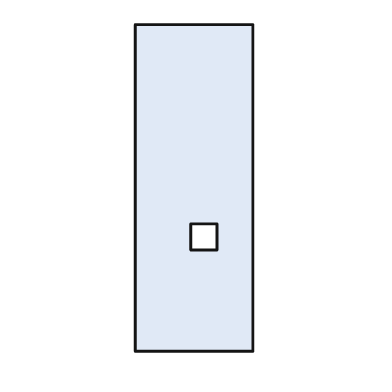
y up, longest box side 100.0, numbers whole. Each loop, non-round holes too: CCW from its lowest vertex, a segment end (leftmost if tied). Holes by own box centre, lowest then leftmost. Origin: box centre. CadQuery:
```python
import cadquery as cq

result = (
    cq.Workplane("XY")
    .moveTo(-18.0, -50.0)
    .lineTo(18.0, -50.0)
    .lineTo(18.0, 50.0)
    .lineTo(-18.0, 50.0)
    .close()
    .moveTo(-1.0, -19.0)
    .lineTo(7.0, -19.0)
    .lineTo(7.0, -11.0)
    .lineTo(-1.0, -11.0)
    .close()
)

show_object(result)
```